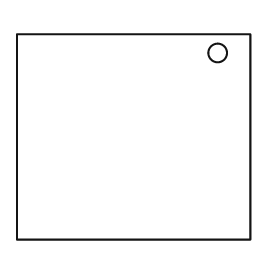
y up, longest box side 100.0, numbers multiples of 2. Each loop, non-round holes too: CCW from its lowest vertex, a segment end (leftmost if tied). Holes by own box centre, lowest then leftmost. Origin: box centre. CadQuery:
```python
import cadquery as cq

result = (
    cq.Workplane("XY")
    .moveTo(-50.0, -44.0)
    .lineTo(50.0, -44.0)
    .lineTo(50.0, 44.0)
    .lineTo(-50.0, 44.0)
    .close()
    .moveTo(36.0, 36.0)
    .circle(4.0)
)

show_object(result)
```